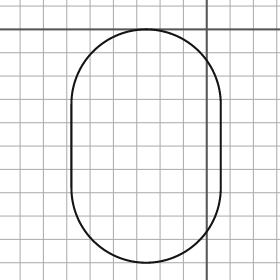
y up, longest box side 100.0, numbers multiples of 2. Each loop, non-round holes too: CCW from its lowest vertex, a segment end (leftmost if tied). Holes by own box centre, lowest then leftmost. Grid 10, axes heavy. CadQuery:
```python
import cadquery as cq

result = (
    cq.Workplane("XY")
    .moveTo(-58.0, -68.0)
    .threePointArc((-26.0, -100.0), (6.0, -68.0))
    .lineTo(6.0, -32.0)
    .threePointArc((-26.0, 0.0), (-58.0, -32.0))
    .close()
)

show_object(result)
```